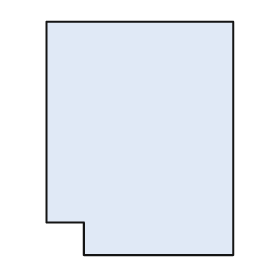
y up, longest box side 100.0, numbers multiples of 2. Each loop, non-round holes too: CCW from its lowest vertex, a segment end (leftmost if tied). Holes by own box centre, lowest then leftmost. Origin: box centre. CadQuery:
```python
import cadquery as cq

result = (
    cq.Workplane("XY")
    .moveTo(-24.0, -50.0)
    .lineTo(40.0, -50.0)
    .lineTo(40.0, 50.0)
    .lineTo(-40.0, 50.0)
    .lineTo(-40.0, -36.0)
    .lineTo(-24.0, -36.0)
    .close()
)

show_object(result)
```